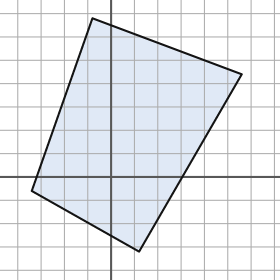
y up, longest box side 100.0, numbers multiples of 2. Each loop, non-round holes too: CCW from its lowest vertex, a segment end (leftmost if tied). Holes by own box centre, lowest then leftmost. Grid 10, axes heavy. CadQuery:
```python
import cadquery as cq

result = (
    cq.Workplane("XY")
    .moveTo(12.0, -32.0)
    .lineTo(56.0, 44.0)
    .lineTo(-8.0, 68.0)
    .lineTo(-34.0, -6.0)
    .close()
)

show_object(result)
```